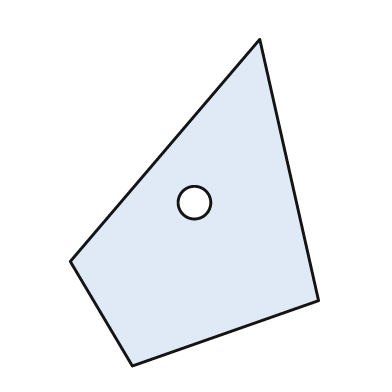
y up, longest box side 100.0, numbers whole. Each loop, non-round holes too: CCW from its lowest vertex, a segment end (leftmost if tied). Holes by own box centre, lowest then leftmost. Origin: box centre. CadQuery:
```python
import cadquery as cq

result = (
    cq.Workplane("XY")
    .moveTo(-19.0, -50.0)
    .lineTo(38.0, -30.0)
    .lineTo(20.0, 50.0)
    .lineTo(-38.0, -18.0)
    .close()
    .moveTo(0.0, 0.0)
    .circle(5.0)
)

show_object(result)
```